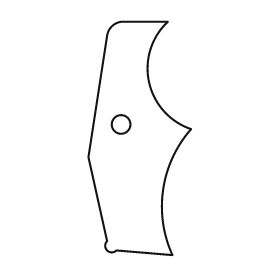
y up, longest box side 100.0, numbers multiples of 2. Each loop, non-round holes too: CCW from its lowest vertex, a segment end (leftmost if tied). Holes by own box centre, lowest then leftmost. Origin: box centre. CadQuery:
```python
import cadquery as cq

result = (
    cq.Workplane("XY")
    .moveTo(14.0, -50.0)
    .threePointArc((10.0, -22.0), (22.0, 4.0))
    .threePointArc((4.0, 24.0), (12.0, 50.0))
    .lineTo(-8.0, 50.0)
    .threePointArc((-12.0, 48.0), (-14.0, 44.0))
    .lineTo(-22.0, -8.0)
    .lineTo(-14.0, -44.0)
    .threePointArc((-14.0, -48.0), (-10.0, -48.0))
    .close()
    .moveTo(-8.0, 6.0)
    .circle(4.0)
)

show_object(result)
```